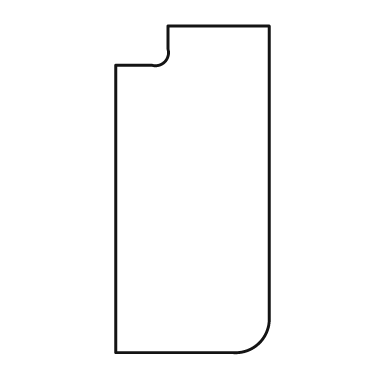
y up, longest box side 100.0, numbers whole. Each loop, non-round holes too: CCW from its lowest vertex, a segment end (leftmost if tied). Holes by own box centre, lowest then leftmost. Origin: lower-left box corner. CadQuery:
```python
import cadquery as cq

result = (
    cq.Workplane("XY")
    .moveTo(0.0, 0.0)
    .lineTo(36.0, 0.0)
    .threePointArc((44.0, 3.0), (47.0, 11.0))
    .lineTo(47.0, 100.0)
    .lineTo(16.0, 100.0)
    .lineTo(16.0, 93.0)
    .threePointArc((15.0, 89.0), (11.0, 88.0))
    .lineTo(0.0, 88.0)
    .close()
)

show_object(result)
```